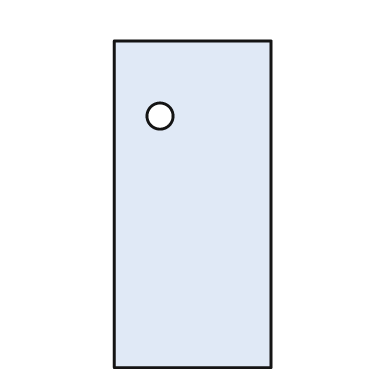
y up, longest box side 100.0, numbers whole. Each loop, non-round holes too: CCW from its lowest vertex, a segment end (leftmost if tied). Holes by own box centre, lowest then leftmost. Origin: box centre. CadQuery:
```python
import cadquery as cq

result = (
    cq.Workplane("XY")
    .moveTo(-24.0, -50.0)
    .lineTo(24.0, -50.0)
    .lineTo(24.0, 50.0)
    .lineTo(-24.0, 50.0)
    .close()
    .moveTo(-10.0, 27.0)
    .circle(4.0)
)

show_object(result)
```